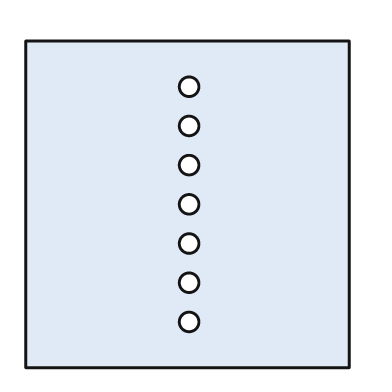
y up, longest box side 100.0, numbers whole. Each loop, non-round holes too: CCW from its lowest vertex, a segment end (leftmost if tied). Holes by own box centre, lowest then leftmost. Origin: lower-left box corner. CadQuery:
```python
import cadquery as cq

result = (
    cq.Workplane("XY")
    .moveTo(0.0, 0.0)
    .lineTo(99.0, 0.0)
    .lineTo(99.0, 100.0)
    .lineTo(0.0, 100.0)
    .close()
    .moveTo(50.0, 14.0)
    .circle(3.0)
    .moveTo(50.0, 26.0)
    .circle(3.0)
    .moveTo(50.0, 38.0)
    .circle(3.0)
    .moveTo(50.0, 50.0)
    .circle(3.0)
    .moveTo(50.0, 62.0)
    .circle(3.0)
    .moveTo(50.0, 74.0)
    .circle(3.0)
    .moveTo(50.0, 86.0)
    .circle(3.0)
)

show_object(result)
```